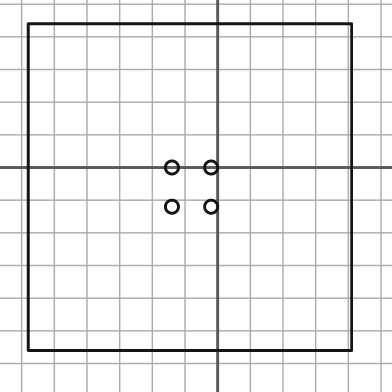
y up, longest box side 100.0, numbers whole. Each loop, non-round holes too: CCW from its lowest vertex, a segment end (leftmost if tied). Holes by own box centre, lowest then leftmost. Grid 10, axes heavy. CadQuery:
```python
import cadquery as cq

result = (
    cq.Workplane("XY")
    .moveTo(-58.0, -56.0)
    .lineTo(41.0, -56.0)
    .lineTo(41.0, 44.0)
    .lineTo(-58.0, 44.0)
    .close()
    .moveTo(-14.0, -12.0)
    .circle(2.0)
    .moveTo(-2.0, -12.0)
    .circle(2.0)
    .moveTo(-14.0, 0.0)
    .circle(2.0)
    .moveTo(-2.0, 0.0)
    .circle(2.0)
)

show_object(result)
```